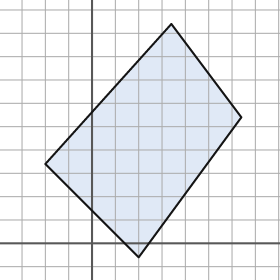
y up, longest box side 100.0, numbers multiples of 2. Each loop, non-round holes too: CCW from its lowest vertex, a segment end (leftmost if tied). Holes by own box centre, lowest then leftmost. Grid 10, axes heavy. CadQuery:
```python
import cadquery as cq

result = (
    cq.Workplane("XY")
    .moveTo(20.0, -6.0)
    .lineTo(64.0, 54.0)
    .lineTo(34.0, 94.0)
    .lineTo(-20.0, 34.0)
    .close()
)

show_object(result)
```